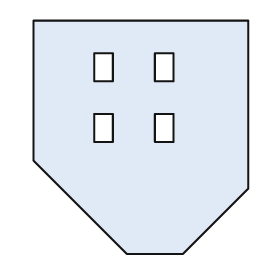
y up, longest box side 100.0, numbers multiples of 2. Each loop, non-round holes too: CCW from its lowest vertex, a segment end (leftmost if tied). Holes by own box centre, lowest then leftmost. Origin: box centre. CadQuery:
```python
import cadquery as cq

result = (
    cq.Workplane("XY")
    .moveTo(-6.0, -50.0)
    .lineTo(18.0, -50.0)
    .lineTo(46.0, -22.0)
    .lineTo(46.0, 50.0)
    .lineTo(-46.0, 50.0)
    .lineTo(-46.0, -10.0)
    .close()
    .moveTo(-20.0, -2.0)
    .lineTo(-12.0, -2.0)
    .lineTo(-12.0, 10.0)
    .lineTo(-20.0, 10.0)
    .close()
    .moveTo(6.0, -2.0)
    .lineTo(14.0, -2.0)
    .lineTo(14.0, 10.0)
    .lineTo(6.0, 10.0)
    .close()
    .moveTo(-20.0, 24.0)
    .lineTo(-12.0, 24.0)
    .lineTo(-12.0, 36.0)
    .lineTo(-20.0, 36.0)
    .close()
    .moveTo(6.0, 24.0)
    .lineTo(14.0, 24.0)
    .lineTo(14.0, 36.0)
    .lineTo(6.0, 36.0)
    .close()
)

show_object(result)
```